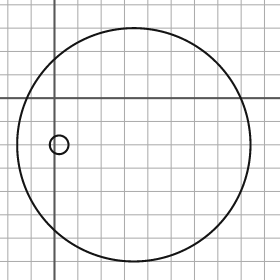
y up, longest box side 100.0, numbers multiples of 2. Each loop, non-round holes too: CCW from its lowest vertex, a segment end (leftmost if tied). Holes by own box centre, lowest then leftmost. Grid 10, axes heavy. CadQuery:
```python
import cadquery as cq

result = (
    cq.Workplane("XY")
    .moveTo(34.0, -20.0)
    .circle(50.0)
    .moveTo(2.0, -20.0)
    .circle(4.0)
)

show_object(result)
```